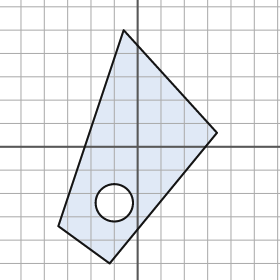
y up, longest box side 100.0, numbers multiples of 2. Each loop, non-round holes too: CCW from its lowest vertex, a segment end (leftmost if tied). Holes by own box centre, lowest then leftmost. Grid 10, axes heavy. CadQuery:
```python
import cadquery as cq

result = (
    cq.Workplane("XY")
    .moveTo(-12.0, -50.0)
    .lineTo(34.0, 6.0)
    .lineTo(-6.0, 50.0)
    .lineTo(-34.0, -34.0)
    .close()
    .moveTo(-10.0, -24.0)
    .circle(8.0)
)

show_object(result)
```